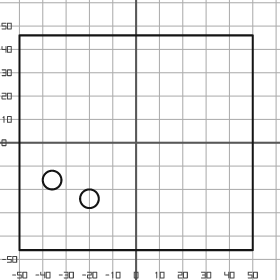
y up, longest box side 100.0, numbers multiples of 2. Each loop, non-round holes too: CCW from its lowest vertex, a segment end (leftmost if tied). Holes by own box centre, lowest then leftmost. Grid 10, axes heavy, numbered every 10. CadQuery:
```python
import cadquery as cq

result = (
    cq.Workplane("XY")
    .moveTo(-50.0, -46.0)
    .lineTo(50.0, -46.0)
    .lineTo(50.0, 46.0)
    .lineTo(-50.0, 46.0)
    .close()
    .moveTo(-20.0, -24.0)
    .circle(4.0)
    .moveTo(-36.0, -16.0)
    .circle(4.0)
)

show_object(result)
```